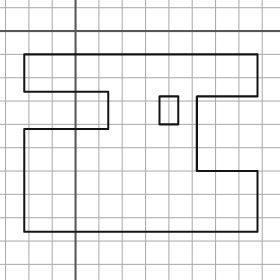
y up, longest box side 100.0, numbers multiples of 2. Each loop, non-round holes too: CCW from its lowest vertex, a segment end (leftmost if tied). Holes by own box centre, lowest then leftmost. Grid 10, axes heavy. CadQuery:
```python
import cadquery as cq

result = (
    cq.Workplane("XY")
    .moveTo(-22.0, -86.0)
    .lineTo(78.0, -86.0)
    .lineTo(78.0, -60.0)
    .lineTo(52.0, -60.0)
    .lineTo(52.0, -28.0)
    .lineTo(78.0, -28.0)
    .lineTo(78.0, -10.0)
    .lineTo(-22.0, -10.0)
    .lineTo(-22.0, -26.0)
    .lineTo(14.0, -26.0)
    .lineTo(14.0, -42.0)
    .lineTo(-22.0, -42.0)
    .close()
    .moveTo(36.0, -40.0)
    .lineTo(44.0, -40.0)
    .lineTo(44.0, -28.0)
    .lineTo(36.0, -28.0)
    .close()
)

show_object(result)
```